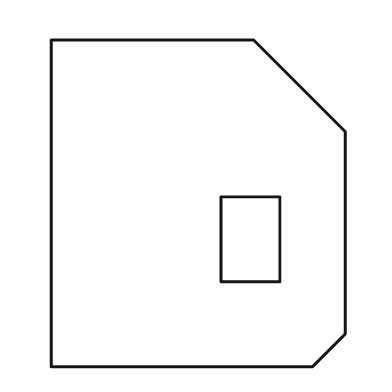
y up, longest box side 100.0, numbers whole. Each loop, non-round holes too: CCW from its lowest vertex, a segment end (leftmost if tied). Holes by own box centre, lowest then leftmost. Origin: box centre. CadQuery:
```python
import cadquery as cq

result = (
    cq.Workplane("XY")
    .moveTo(-45.0, -50.0)
    .lineTo(35.0, -50.0)
    .lineTo(45.0, -40.0)
    .lineTo(45.0, 22.0)
    .lineTo(17.0, 50.0)
    .lineTo(-45.0, 50.0)
    .close()
    .moveTo(7.0, -24.0)
    .lineTo(25.0, -24.0)
    .lineTo(25.0, 2.0)
    .lineTo(7.0, 2.0)
    .close()
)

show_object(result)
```